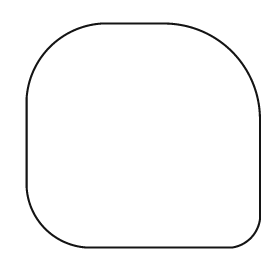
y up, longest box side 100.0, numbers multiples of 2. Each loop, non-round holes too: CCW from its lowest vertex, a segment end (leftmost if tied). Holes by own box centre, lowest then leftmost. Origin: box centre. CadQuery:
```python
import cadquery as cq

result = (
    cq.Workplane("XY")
    .moveTo(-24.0, -48.0)
    .lineTo(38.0, -48.0)
    .threePointArc((46.0, -44.0), (50.0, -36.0))
    .lineTo(50.0, 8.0)
    .threePointArc((38.0, 36.0), (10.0, 48.0))
    .lineTo(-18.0, 48.0)
    .threePointArc((-40.0, 38.0), (-50.0, 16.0))
    .lineTo(-50.0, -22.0)
    .threePointArc((-42.0, -40.0), (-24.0, -48.0))
    .close()
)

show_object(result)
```